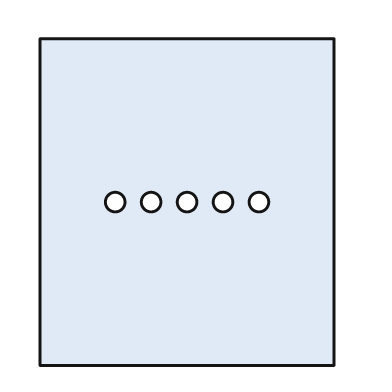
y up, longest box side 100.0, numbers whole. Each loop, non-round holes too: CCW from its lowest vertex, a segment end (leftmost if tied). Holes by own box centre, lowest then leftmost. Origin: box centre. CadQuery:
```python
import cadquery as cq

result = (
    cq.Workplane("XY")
    .moveTo(-45.0, -50.0)
    .lineTo(45.0, -50.0)
    .lineTo(45.0, 50.0)
    .lineTo(-45.0, 50.0)
    .close()
    .moveTo(-22.0, 0.0)
    .circle(3.0)
    .moveTo(-11.0, 0.0)
    .circle(3.0)
    .moveTo(0.0, 0.0)
    .circle(3.0)
    .moveTo(11.0, 0.0)
    .circle(3.0)
    .moveTo(22.0, 0.0)
    .circle(3.0)
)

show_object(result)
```